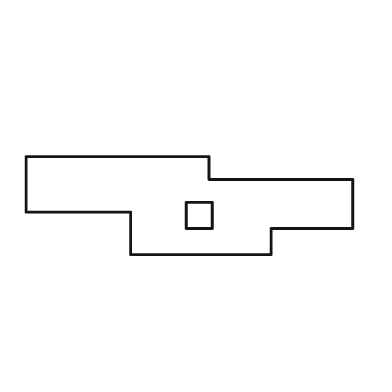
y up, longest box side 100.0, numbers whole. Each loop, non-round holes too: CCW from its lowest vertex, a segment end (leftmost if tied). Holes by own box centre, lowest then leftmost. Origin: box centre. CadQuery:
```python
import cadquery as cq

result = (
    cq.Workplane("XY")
    .moveTo(-18.0, -15.0)
    .lineTo(25.0, -15.0)
    .lineTo(25.0, -7.0)
    .lineTo(50.0, -7.0)
    .lineTo(50.0, 8.0)
    .lineTo(6.0, 8.0)
    .lineTo(6.0, 15.0)
    .lineTo(-50.0, 15.0)
    .lineTo(-50.0, -2.0)
    .lineTo(-18.0, -2.0)
    .close()
    .moveTo(-1.0, -7.0)
    .lineTo(7.0, -7.0)
    .lineTo(7.0, 1.0)
    .lineTo(-1.0, 1.0)
    .close()
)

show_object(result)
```